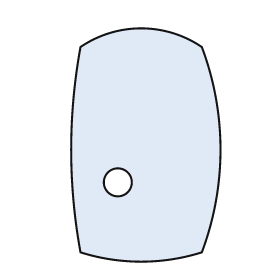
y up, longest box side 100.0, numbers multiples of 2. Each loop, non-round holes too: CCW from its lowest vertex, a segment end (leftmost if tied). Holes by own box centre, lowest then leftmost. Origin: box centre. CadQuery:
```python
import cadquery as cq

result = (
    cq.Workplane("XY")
    .moveTo(-28.0, -46.0)
    .threePointArc((-2.0, -50.0), (24.0, -46.0))
    .threePointArc((32.0, -2.0), (24.0, 42.0))
    .threePointArc((-2.0, 50.0), (-28.0, 42.0))
    .threePointArc((-32.0, -2.0), (-28.0, -46.0))
    .close()
    .moveTo(-12.0, -16.0)
    .circle(6.0)
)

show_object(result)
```